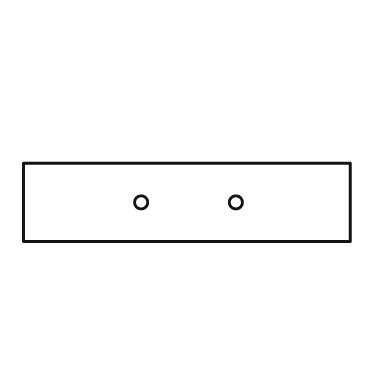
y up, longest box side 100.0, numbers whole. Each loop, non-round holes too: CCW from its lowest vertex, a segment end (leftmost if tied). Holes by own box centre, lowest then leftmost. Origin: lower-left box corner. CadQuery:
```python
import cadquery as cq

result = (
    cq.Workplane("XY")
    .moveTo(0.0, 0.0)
    .lineTo(100.0, 0.0)
    .lineTo(100.0, 24.0)
    .lineTo(0.0, 24.0)
    .close()
    .moveTo(36.0, 12.0)
    .circle(2.0)
    .moveTo(65.0, 12.0)
    .circle(2.0)
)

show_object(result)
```